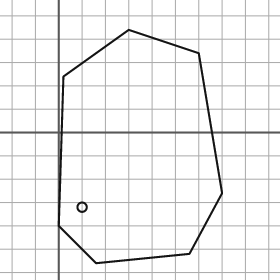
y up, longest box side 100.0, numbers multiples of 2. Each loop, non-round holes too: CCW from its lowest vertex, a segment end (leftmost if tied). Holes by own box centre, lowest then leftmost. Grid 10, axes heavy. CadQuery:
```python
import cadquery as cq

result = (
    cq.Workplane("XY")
    .moveTo(16.0, -56.0)
    .lineTo(56.0, -52.0)
    .lineTo(70.0, -26.0)
    .lineTo(60.0, 34.0)
    .lineTo(30.0, 44.0)
    .lineTo(2.0, 24.0)
    .lineTo(0.0, -40.0)
    .close()
    .moveTo(10.0, -32.0)
    .circle(2.0)
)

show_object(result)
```